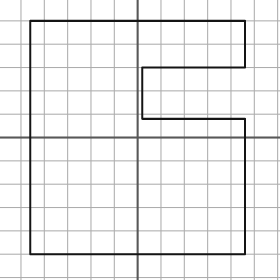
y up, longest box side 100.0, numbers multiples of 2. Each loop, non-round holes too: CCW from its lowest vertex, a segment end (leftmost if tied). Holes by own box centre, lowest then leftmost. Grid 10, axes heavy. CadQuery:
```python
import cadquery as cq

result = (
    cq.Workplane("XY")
    .moveTo(-46.0, -50.0)
    .lineTo(46.0, -50.0)
    .lineTo(46.0, 8.0)
    .lineTo(2.0, 8.0)
    .lineTo(2.0, 30.0)
    .lineTo(46.0, 30.0)
    .lineTo(46.0, 50.0)
    .lineTo(-46.0, 50.0)
    .close()
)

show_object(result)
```